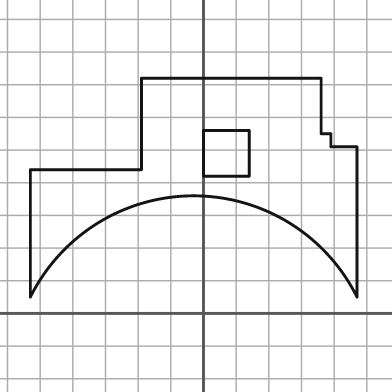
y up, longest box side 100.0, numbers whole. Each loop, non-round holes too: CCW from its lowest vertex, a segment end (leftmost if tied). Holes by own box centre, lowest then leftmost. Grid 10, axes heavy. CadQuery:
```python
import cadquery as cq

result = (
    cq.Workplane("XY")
    .moveTo(-53.0, 5.0)
    .threePointArc((-3.0, 36.0), (47.0, 5.0))
    .lineTo(47.0, 51.0)
    .lineTo(39.0, 51.0)
    .lineTo(39.0, 55.0)
    .lineTo(36.0, 55.0)
    .lineTo(36.0, 72.0)
    .lineTo(-19.0, 72.0)
    .lineTo(-19.0, 44.0)
    .lineTo(-53.0, 44.0)
    .close()
    .moveTo(0.0, 42.0)
    .lineTo(14.0, 42.0)
    .lineTo(14.0, 56.0)
    .lineTo(0.0, 56.0)
    .close()
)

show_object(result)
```